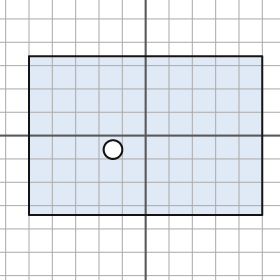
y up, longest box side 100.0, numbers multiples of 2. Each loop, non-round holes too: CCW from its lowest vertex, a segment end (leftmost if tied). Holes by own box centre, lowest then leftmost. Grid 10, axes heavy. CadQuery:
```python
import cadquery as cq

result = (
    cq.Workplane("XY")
    .moveTo(-50.0, -34.0)
    .lineTo(50.0, -34.0)
    .lineTo(50.0, 34.0)
    .lineTo(-50.0, 34.0)
    .close()
    .moveTo(-14.0, -6.0)
    .circle(4.0)
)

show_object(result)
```